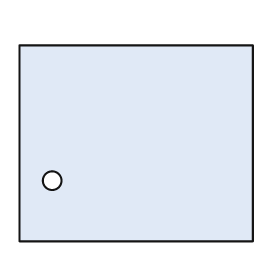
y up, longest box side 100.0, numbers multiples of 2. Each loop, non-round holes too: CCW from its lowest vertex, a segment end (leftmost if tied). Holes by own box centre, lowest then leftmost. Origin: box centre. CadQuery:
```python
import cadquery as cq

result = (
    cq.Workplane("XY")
    .moveTo(-50.0, -42.0)
    .lineTo(50.0, -42.0)
    .lineTo(50.0, 42.0)
    .lineTo(-50.0, 42.0)
    .close()
    .moveTo(-36.0, -16.0)
    .circle(4.0)
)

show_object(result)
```